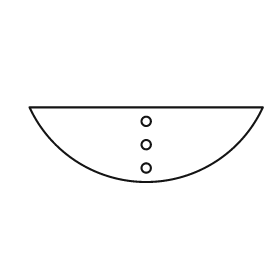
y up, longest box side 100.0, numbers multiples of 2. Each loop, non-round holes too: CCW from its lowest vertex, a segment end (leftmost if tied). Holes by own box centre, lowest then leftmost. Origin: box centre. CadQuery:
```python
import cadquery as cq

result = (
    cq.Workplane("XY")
    .moveTo(-50.0, 16.0)
    .threePointArc((0.0, -16.0), (50.0, 16.0))
    .close()
    .moveTo(0.0, -10.0)
    .circle(2.0)
    .moveTo(0.0, 0.0)
    .circle(2.0)
    .moveTo(0.0, 10.0)
    .circle(2.0)
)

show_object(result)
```